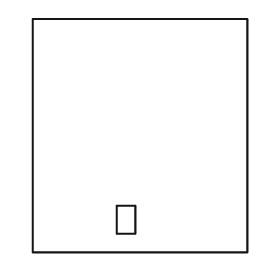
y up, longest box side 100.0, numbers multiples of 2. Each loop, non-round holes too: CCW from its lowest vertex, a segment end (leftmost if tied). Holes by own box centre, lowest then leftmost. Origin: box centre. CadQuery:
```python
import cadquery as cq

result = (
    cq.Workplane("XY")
    .moveTo(-46.0, -50.0)
    .lineTo(46.0, -50.0)
    .lineTo(46.0, 50.0)
    .lineTo(-46.0, 50.0)
    .close()
    .moveTo(-10.0, -42.0)
    .lineTo(-2.0, -42.0)
    .lineTo(-2.0, -30.0)
    .lineTo(-10.0, -30.0)
    .close()
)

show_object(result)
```